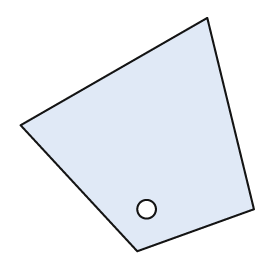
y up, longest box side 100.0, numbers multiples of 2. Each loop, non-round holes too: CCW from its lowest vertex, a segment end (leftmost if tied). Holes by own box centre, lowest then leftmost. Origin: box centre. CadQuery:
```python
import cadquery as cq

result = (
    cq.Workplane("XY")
    .moveTo(0.0, -50.0)
    .lineTo(50.0, -32.0)
    .lineTo(30.0, 50.0)
    .lineTo(-50.0, 4.0)
    .close()
    .moveTo(4.0, -32.0)
    .circle(4.0)
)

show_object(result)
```